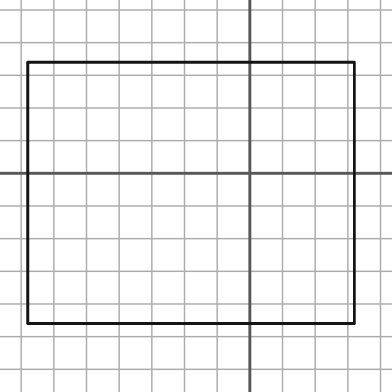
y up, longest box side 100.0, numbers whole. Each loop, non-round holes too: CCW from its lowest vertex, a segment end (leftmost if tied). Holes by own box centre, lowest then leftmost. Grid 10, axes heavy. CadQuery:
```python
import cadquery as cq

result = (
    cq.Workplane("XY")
    .moveTo(-68.0, -46.0)
    .lineTo(32.0, -46.0)
    .lineTo(32.0, 34.0)
    .lineTo(-68.0, 34.0)
    .close()
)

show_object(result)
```